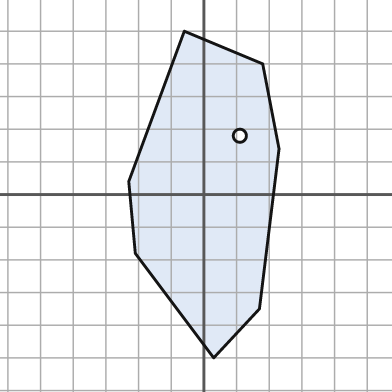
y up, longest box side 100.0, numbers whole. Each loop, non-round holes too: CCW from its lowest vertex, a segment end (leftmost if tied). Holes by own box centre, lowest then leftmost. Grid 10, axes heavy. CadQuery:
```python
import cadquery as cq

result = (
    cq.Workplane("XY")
    .moveTo(3.0, -50.0)
    .lineTo(17.0, -35.0)
    .lineTo(23.0, 14.0)
    .lineTo(18.0, 40.0)
    .lineTo(-6.0, 50.0)
    .lineTo(-23.0, 4.0)
    .lineTo(-21.0, -18.0)
    .close()
    .moveTo(11.0, 18.0)
    .circle(2.0)
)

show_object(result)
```